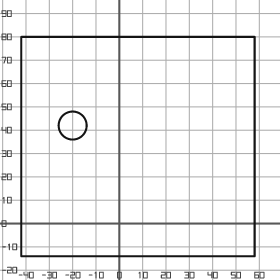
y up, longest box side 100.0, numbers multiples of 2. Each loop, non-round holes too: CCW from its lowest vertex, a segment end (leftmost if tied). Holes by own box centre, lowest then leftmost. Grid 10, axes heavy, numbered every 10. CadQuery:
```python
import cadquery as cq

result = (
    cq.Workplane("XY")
    .moveTo(-42.0, -14.0)
    .lineTo(58.0, -14.0)
    .lineTo(58.0, 80.0)
    .lineTo(-42.0, 80.0)
    .close()
    .moveTo(-20.0, 42.0)
    .circle(6.0)
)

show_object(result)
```